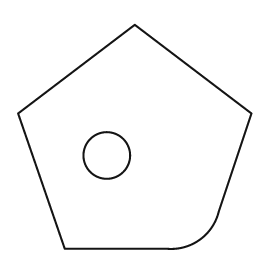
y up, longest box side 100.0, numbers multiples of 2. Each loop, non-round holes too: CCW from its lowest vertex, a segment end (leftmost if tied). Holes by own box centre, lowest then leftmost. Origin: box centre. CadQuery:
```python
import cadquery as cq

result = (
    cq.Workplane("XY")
    .moveTo(-30.0, -48.0)
    .lineTo(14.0, -48.0)
    .threePointArc((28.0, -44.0), (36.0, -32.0))
    .lineTo(50.0, 10.0)
    .lineTo(0.0, 48.0)
    .lineTo(-50.0, 10.0)
    .close()
    .moveTo(-12.0, -8.0)
    .circle(10.0)
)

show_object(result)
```